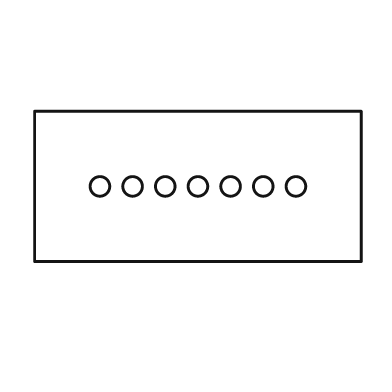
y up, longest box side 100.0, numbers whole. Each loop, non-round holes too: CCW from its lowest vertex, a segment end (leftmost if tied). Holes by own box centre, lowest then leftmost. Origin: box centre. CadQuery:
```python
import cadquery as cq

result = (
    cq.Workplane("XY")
    .moveTo(-50.0, -23.0)
    .lineTo(50.0, -23.0)
    .lineTo(50.0, 23.0)
    .lineTo(-50.0, 23.0)
    .close()
    .moveTo(-30.0, 0.0)
    .circle(3.0)
    .moveTo(-20.0, 0.0)
    .circle(3.0)
    .moveTo(-10.0, 0.0)
    .circle(3.0)
    .moveTo(0.0, 0.0)
    .circle(3.0)
    .moveTo(10.0, 0.0)
    .circle(3.0)
    .moveTo(20.0, 0.0)
    .circle(3.0)
    .moveTo(30.0, 0.0)
    .circle(3.0)
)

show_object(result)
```